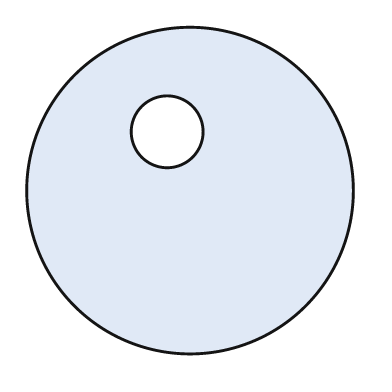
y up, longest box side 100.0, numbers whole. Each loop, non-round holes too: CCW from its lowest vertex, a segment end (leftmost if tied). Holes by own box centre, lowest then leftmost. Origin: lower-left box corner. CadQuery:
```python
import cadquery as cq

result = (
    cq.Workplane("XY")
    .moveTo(50.0, 50.0)
    .circle(50.0)
    .moveTo(43.0, 68.0)
    .circle(11.0)
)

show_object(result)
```